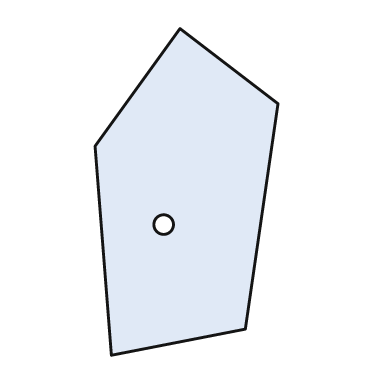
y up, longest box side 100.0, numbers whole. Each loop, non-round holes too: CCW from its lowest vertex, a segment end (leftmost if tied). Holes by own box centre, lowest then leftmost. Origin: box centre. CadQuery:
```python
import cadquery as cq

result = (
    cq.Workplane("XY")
    .moveTo(-23.0, -50.0)
    .lineTo(18.0, -42.0)
    .lineTo(28.0, 27.0)
    .lineTo(-2.0, 50.0)
    .lineTo(-28.0, 14.0)
    .close()
    .moveTo(-7.0, -10.0)
    .circle(3.0)
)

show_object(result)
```